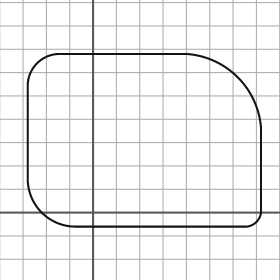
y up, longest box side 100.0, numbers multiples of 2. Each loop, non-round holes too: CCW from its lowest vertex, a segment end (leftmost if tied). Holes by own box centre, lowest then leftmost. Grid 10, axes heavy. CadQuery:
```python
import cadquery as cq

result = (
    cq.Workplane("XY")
    .moveTo(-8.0, -6.0)
    .lineTo(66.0, -6.0)
    .threePointArc((70.0, -4.0), (72.0, 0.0))
    .lineTo(72.0, 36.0)
    .threePointArc((62.0, 58.0), (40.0, 68.0))
    .lineTo(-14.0, 68.0)
    .threePointArc((-24.0, 64.0), (-28.0, 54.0))
    .lineTo(-28.0, 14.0)
    .threePointArc((-22.0, 0.0), (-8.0, -6.0))
    .close()
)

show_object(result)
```